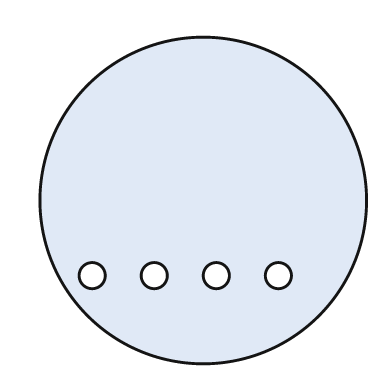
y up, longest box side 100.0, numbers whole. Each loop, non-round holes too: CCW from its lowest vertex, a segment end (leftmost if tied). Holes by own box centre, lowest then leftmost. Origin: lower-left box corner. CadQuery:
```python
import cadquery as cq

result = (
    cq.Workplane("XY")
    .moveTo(50.0, 50.0)
    .circle(50.0)
    .moveTo(16.0, 27.0)
    .circle(4.0)
    .moveTo(35.0, 27.0)
    .circle(4.0)
    .moveTo(54.0, 27.0)
    .circle(4.0)
    .moveTo(73.0, 27.0)
    .circle(4.0)
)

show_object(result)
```